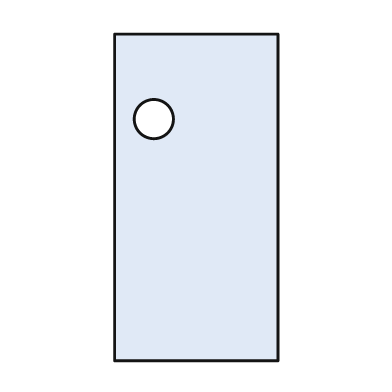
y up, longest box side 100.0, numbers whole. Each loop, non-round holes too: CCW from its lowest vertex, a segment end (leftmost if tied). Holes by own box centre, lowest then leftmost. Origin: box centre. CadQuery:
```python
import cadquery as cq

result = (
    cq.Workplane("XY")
    .moveTo(-25.0, -50.0)
    .lineTo(25.0, -50.0)
    .lineTo(25.0, 50.0)
    .lineTo(-25.0, 50.0)
    .close()
    .moveTo(-13.0, 24.0)
    .circle(6.0)
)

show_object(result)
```